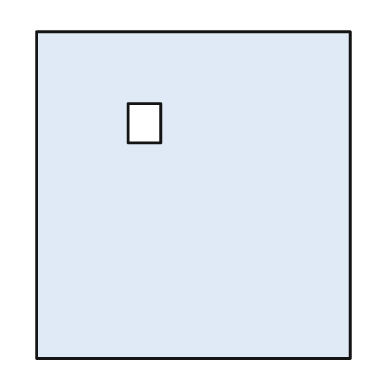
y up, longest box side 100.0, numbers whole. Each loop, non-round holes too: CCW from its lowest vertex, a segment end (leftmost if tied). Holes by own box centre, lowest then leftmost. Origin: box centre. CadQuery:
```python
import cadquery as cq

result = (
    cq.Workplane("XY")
    .moveTo(-48.0, -50.0)
    .lineTo(48.0, -50.0)
    .lineTo(48.0, 50.0)
    .lineTo(-48.0, 50.0)
    .close()
    .moveTo(-20.0, 16.0)
    .lineTo(-10.0, 16.0)
    .lineTo(-10.0, 28.0)
    .lineTo(-20.0, 28.0)
    .close()
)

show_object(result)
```